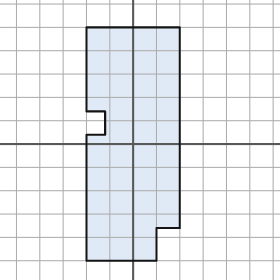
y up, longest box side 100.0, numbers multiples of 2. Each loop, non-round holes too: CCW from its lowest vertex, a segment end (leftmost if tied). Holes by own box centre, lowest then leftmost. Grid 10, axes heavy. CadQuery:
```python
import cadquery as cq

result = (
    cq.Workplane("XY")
    .moveTo(-20.0, -50.0)
    .lineTo(10.0, -50.0)
    .lineTo(10.0, -36.0)
    .lineTo(20.0, -36.0)
    .lineTo(20.0, 50.0)
    .lineTo(-20.0, 50.0)
    .lineTo(-20.0, 14.0)
    .lineTo(-12.0, 14.0)
    .lineTo(-12.0, 4.0)
    .lineTo(-20.0, 4.0)
    .close()
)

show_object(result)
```